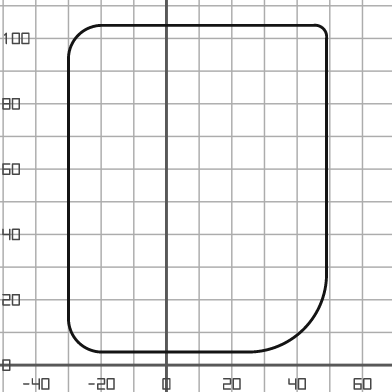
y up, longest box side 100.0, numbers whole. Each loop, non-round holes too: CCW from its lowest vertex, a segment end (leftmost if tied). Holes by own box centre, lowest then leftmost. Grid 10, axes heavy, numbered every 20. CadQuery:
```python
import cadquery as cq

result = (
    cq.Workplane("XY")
    .moveTo(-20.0, 4.0)
    .lineTo(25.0, 4.0)
    .threePointArc((42.0, 11.0), (49.0, 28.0))
    .lineTo(49.0, 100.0)
    .threePointArc((48.0, 103.0), (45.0, 104.0))
    .lineTo(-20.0, 104.0)
    .threePointArc((-27.0, 101.0), (-30.0, 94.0))
    .lineTo(-30.0, 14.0)
    .threePointArc((-27.0, 7.0), (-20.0, 4.0))
    .close()
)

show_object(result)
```